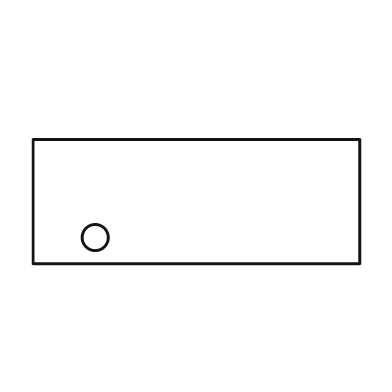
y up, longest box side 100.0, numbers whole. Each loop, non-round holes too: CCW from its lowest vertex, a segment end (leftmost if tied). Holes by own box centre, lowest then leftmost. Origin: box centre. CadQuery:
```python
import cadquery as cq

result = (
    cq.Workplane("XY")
    .moveTo(-50.0, -19.0)
    .lineTo(50.0, -19.0)
    .lineTo(50.0, 19.0)
    .lineTo(-50.0, 19.0)
    .close()
    .moveTo(-31.0, -11.0)
    .circle(4.0)
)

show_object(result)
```